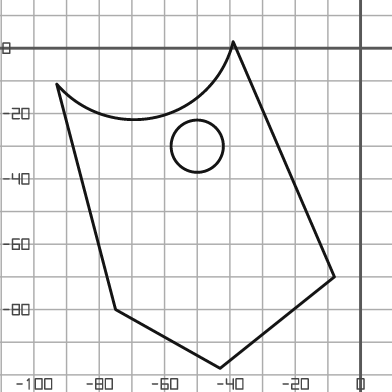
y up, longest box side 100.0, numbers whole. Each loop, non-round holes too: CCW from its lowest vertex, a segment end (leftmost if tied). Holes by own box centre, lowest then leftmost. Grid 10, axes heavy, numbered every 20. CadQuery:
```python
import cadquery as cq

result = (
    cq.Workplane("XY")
    .moveTo(-43.0, -98.0)
    .lineTo(-8.0, -70.0)
    .lineTo(-39.0, 2.0)
    .threePointArc((-62.0, -21.0), (-93.0, -11.0))
    .lineTo(-75.0, -80.0)
    .close()
    .moveTo(-50.0, -30.0)
    .circle(8.0)
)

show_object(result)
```